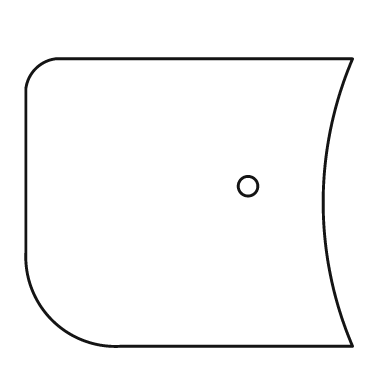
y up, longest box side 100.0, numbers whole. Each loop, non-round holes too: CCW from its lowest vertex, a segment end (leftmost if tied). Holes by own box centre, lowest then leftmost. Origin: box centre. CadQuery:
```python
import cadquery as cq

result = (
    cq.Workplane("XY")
    .moveTo(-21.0, -44.0)
    .lineTo(50.0, -44.0)
    .threePointArc((41.0, 0.0), (50.0, 44.0))
    .lineTo(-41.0, 44.0)
    .threePointArc((-47.0, 41.0), (-50.0, 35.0))
    .lineTo(-50.0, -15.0)
    .threePointArc((-42.0, -36.0), (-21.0, -44.0))
    .close()
    .moveTo(18.0, 5.0)
    .circle(3.0)
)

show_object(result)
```